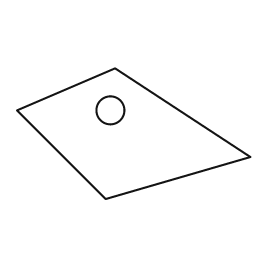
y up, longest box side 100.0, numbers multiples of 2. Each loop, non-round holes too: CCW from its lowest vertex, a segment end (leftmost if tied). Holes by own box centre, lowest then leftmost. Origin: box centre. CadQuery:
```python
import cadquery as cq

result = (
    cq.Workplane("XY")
    .moveTo(-12.0, -28.0)
    .lineTo(50.0, -10.0)
    .lineTo(-8.0, 28.0)
    .lineTo(-50.0, 10.0)
    .close()
    .moveTo(-10.0, 10.0)
    .circle(6.0)
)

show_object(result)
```